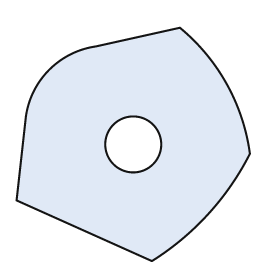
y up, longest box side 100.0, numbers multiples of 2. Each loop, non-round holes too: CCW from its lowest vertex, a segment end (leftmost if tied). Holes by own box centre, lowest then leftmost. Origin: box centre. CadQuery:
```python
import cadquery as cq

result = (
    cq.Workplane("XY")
    .moveTo(8.0, -50.0)
    .threePointArc((32.0, -30.0), (50.0, -4.0))
    .threePointArc((40.0, 26.0), (20.0, 50.0))
    .lineTo(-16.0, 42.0)
    .threePointArc((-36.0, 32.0), (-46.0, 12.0))
    .lineTo(-50.0, -24.0)
    .close()
    .moveTo(0.0, 0.0)
    .circle(12.0)
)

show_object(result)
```